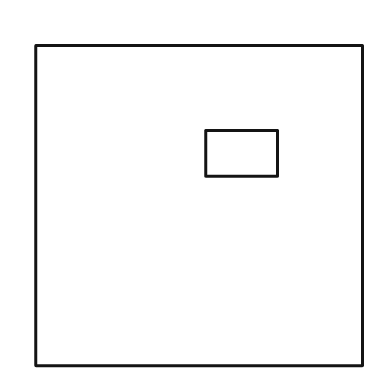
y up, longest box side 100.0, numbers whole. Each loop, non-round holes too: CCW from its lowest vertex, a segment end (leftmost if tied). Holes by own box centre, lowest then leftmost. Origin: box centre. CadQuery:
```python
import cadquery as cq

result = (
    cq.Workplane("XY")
    .moveTo(-50.0, -49.0)
    .lineTo(50.0, -49.0)
    .lineTo(50.0, 49.0)
    .lineTo(-50.0, 49.0)
    .close()
    .moveTo(2.0, 9.0)
    .lineTo(24.0, 9.0)
    .lineTo(24.0, 23.0)
    .lineTo(2.0, 23.0)
    .close()
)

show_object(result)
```